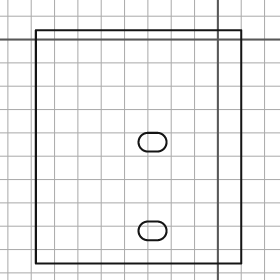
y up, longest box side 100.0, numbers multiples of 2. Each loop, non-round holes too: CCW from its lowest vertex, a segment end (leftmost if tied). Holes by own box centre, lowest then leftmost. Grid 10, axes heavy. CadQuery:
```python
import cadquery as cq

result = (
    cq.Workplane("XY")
    .moveTo(-78.0, -96.0)
    .lineTo(10.0, -96.0)
    .lineTo(10.0, 4.0)
    .lineTo(-78.0, 4.0)
    .close()
    .moveTo(-30.0, -86.0)
    .lineTo(-26.0, -86.0)
    .threePointArc((-22.0, -82.0), (-26.0, -78.0))
    .lineTo(-30.0, -78.0)
    .threePointArc((-34.0, -82.0), (-30.0, -86.0))
    .close()
    .moveTo(-30.0, -48.0)
    .lineTo(-26.0, -48.0)
    .threePointArc((-22.0, -44.0), (-26.0, -40.0))
    .lineTo(-30.0, -40.0)
    .threePointArc((-34.0, -44.0), (-30.0, -48.0))
    .close()
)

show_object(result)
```